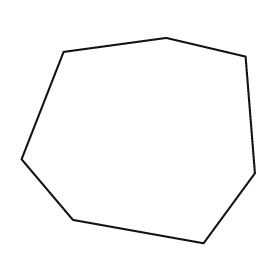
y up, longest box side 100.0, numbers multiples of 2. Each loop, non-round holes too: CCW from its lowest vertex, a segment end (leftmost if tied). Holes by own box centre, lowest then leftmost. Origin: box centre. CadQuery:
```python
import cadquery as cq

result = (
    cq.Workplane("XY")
    .moveTo(28.0, -44.0)
    .lineTo(50.0, -14.0)
    .lineTo(46.0, 36.0)
    .lineTo(12.0, 44.0)
    .lineTo(-32.0, 38.0)
    .lineTo(-50.0, -8.0)
    .lineTo(-28.0, -34.0)
    .close()
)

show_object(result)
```